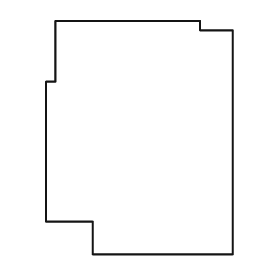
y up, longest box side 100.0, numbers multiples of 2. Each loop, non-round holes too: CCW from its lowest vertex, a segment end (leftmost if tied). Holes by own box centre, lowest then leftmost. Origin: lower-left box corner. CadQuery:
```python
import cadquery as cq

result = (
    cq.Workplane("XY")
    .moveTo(20.0, 0.0)
    .lineTo(80.0, 0.0)
    .lineTo(80.0, 96.0)
    .lineTo(66.0, 96.0)
    .lineTo(66.0, 100.0)
    .lineTo(4.0, 100.0)
    .lineTo(4.0, 74.0)
    .lineTo(0.0, 74.0)
    .lineTo(0.0, 14.0)
    .lineTo(20.0, 14.0)
    .close()
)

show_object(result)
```